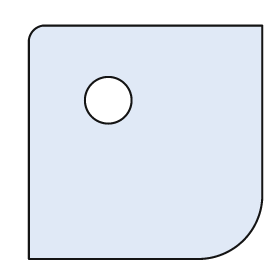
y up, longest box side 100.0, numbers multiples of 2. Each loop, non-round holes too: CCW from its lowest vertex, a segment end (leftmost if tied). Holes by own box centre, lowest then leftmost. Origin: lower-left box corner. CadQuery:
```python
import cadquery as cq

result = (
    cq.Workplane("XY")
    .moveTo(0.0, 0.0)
    .lineTo(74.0, 0.0)
    .threePointArc((92.0, 8.0), (100.0, 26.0))
    .lineTo(100.0, 100.0)
    .lineTo(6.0, 100.0)
    .threePointArc((2.0, 98.0), (0.0, 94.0))
    .close()
    .moveTo(34.0, 68.0)
    .circle(10.0)
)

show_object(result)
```